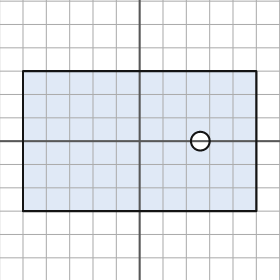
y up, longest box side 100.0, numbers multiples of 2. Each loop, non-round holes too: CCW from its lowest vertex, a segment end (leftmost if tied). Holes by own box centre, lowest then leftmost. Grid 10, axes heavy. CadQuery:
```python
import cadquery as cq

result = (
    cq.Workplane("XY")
    .moveTo(-50.0, -30.0)
    .lineTo(50.0, -30.0)
    .lineTo(50.0, 30.0)
    .lineTo(-50.0, 30.0)
    .close()
    .moveTo(26.0, 0.0)
    .circle(4.0)
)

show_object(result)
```